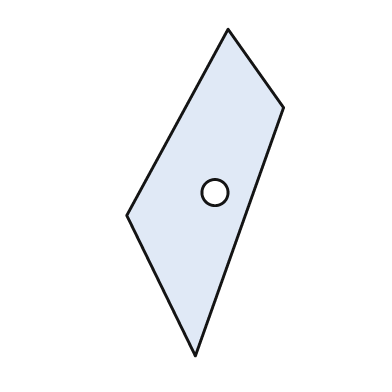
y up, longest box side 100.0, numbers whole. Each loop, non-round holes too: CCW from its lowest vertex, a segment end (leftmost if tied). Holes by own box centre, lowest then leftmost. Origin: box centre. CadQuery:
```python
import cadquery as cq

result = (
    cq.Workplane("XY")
    .moveTo(-3.0, -50.0)
    .lineTo(24.0, 26.0)
    .lineTo(7.0, 50.0)
    .lineTo(-24.0, -7.0)
    .close()
    .moveTo(3.0, 0.0)
    .circle(4.0)
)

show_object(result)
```